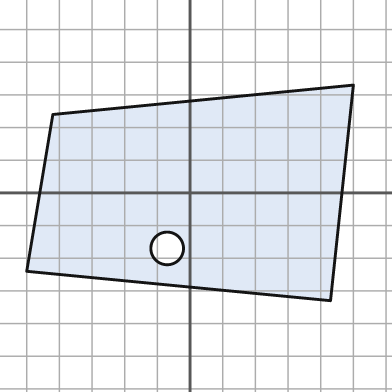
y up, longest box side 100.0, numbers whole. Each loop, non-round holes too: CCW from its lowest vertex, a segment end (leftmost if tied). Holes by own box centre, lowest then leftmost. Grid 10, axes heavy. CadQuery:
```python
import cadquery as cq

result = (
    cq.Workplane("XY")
    .moveTo(43.0, -33.0)
    .lineTo(50.0, 33.0)
    .lineTo(-42.0, 24.0)
    .lineTo(-50.0, -24.0)
    .close()
    .moveTo(-7.0, -17.0)
    .circle(5.0)
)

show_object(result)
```